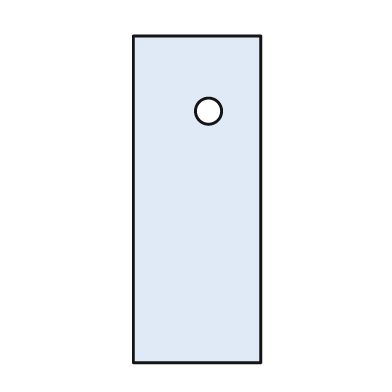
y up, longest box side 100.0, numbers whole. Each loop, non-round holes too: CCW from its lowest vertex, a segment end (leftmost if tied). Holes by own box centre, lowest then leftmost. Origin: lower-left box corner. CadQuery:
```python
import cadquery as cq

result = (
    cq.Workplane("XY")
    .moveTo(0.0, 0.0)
    .lineTo(39.0, 0.0)
    .lineTo(39.0, 100.0)
    .lineTo(0.0, 100.0)
    .close()
    .moveTo(23.0, 77.0)
    .circle(4.0)
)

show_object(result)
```